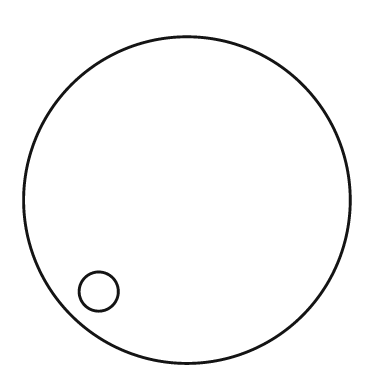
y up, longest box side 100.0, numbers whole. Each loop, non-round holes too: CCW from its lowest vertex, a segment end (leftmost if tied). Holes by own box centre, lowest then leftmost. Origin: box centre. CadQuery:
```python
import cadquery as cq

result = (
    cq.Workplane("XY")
    .moveTo(0.0, 0.0)
    .circle(50.0)
    .moveTo(-27.0, -28.0)
    .circle(6.0)
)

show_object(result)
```